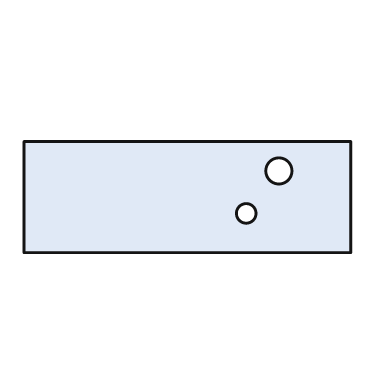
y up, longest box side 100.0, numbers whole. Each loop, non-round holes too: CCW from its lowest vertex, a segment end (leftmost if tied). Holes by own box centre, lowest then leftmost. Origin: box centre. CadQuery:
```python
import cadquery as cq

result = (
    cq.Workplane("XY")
    .moveTo(-50.0, -17.0)
    .lineTo(50.0, -17.0)
    .lineTo(50.0, 17.0)
    .lineTo(-50.0, 17.0)
    .close()
    .moveTo(18.0, -5.0)
    .circle(3.0)
    .moveTo(28.0, 8.0)
    .circle(4.0)
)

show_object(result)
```